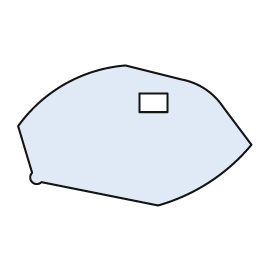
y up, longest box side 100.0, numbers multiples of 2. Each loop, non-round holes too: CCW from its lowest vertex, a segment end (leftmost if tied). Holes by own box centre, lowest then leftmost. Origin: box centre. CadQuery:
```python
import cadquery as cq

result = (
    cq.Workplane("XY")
    .moveTo(10.0, -30.0)
    .threePointArc((32.0, -20.0), (50.0, -4.0))
    .lineTo(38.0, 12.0)
    .threePointArc((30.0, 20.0), (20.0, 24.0))
    .lineTo(-4.0, 30.0)
    .threePointArc((-30.0, 22.0), (-50.0, 4.0))
    .lineTo(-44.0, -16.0)
    .threePointArc((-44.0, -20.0), (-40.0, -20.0))
    .close()
    .moveTo(2.0, 10.0)
    .lineTo(14.0, 10.0)
    .lineTo(14.0, 18.0)
    .lineTo(2.0, 18.0)
    .close()
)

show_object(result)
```